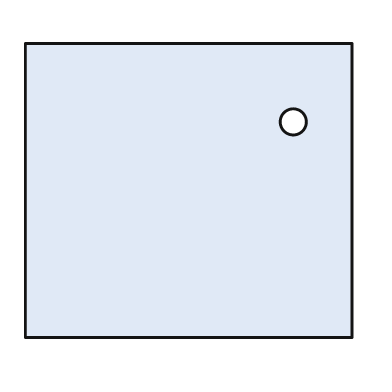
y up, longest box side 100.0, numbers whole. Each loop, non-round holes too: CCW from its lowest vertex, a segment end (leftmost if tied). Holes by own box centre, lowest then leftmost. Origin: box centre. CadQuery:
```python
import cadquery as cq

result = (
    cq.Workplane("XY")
    .moveTo(-50.0, -45.0)
    .lineTo(50.0, -45.0)
    .lineTo(50.0, 45.0)
    .lineTo(-50.0, 45.0)
    .close()
    .moveTo(32.0, 21.0)
    .circle(4.0)
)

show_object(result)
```